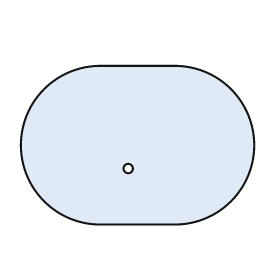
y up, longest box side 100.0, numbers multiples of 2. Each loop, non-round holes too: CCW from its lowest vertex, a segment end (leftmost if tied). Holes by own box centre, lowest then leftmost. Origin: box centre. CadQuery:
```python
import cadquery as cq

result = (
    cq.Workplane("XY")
    .moveTo(-16.0, -34.0)
    .lineTo(16.0, -34.0)
    .threePointArc((50.0, 0.0), (16.0, 34.0))
    .lineTo(-16.0, 34.0)
    .threePointArc((-50.0, 0.0), (-16.0, -34.0))
    .close()
    .moveTo(-4.0, -10.0)
    .circle(2.0)
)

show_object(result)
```